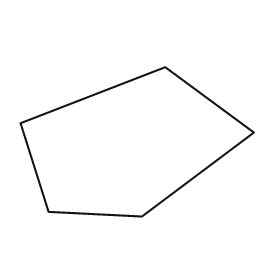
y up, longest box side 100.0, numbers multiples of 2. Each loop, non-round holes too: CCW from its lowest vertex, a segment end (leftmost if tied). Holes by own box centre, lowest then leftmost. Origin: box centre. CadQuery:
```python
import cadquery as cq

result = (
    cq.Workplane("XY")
    .moveTo(2.0, -32.0)
    .lineTo(50.0, 4.0)
    .lineTo(12.0, 32.0)
    .lineTo(-50.0, 8.0)
    .lineTo(-38.0, -30.0)
    .close()
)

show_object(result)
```